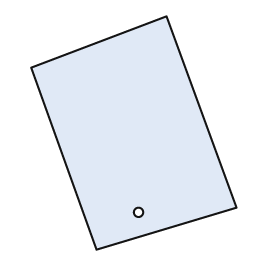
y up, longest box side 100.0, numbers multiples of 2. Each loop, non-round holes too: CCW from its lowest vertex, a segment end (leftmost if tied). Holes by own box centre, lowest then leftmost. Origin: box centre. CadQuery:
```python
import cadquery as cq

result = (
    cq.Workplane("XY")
    .moveTo(-16.0, -50.0)
    .lineTo(44.0, -32.0)
    .lineTo(14.0, 50.0)
    .lineTo(-44.0, 28.0)
    .close()
    .moveTo(2.0, -34.0)
    .circle(2.0)
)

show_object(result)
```